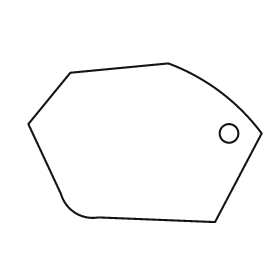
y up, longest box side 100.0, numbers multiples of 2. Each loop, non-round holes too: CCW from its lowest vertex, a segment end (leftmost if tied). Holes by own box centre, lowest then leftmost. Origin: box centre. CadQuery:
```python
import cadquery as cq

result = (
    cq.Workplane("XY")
    .moveTo(30.0, -34.0)
    .lineTo(50.0, 4.0)
    .threePointArc((32.0, 22.0), (10.0, 34.0))
    .lineTo(-32.0, 30.0)
    .lineTo(-50.0, 8.0)
    .lineTo(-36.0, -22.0)
    .threePointArc((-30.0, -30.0), (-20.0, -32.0))
    .close()
    .moveTo(36.0, 4.0)
    .circle(4.0)
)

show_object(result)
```